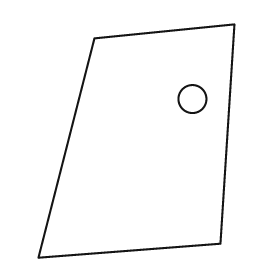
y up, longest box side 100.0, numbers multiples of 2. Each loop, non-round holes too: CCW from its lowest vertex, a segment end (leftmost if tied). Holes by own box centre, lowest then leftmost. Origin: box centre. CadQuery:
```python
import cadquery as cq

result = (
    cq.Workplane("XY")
    .moveTo(-42.0, -50.0)
    .lineTo(36.0, -44.0)
    .lineTo(42.0, 50.0)
    .lineTo(-18.0, 44.0)
    .close()
    .moveTo(24.0, 18.0)
    .circle(6.0)
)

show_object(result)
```